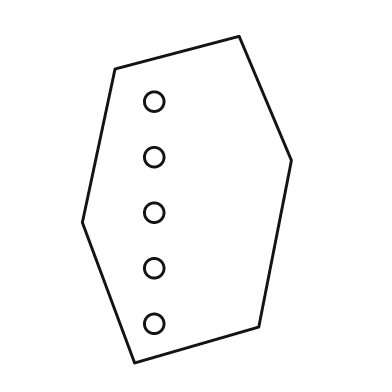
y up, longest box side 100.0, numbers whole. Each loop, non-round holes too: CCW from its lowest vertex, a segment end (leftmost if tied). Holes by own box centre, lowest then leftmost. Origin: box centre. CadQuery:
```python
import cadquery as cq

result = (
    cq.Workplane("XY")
    .moveTo(-16.0, -50.0)
    .lineTo(22.0, -39.0)
    .lineTo(32.0, 12.0)
    .lineTo(16.0, 50.0)
    .lineTo(-22.0, 40.0)
    .lineTo(-32.0, -7.0)
    .close()
    .moveTo(-10.0, -38.0)
    .circle(3.0)
    .moveTo(-10.0, -21.0)
    .circle(3.0)
    .moveTo(-10.0, -4.0)
    .circle(3.0)
    .moveTo(-10.0, 13.0)
    .circle(3.0)
    .moveTo(-10.0, 30.0)
    .circle(3.0)
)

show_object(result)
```